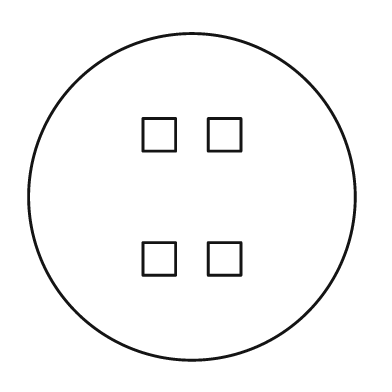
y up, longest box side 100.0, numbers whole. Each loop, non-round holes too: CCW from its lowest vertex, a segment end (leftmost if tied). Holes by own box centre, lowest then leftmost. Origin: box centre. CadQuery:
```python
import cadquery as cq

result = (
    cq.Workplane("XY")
    .moveTo(0.0, 0.0)
    .circle(50.0)
    .moveTo(-15.0, -24.0)
    .lineTo(-5.0, -24.0)
    .lineTo(-5.0, -14.0)
    .lineTo(-15.0, -14.0)
    .close()
    .moveTo(5.0, -24.0)
    .lineTo(15.0, -24.0)
    .lineTo(15.0, -14.0)
    .lineTo(5.0, -14.0)
    .close()
    .moveTo(-15.0, 14.0)
    .lineTo(-5.0, 14.0)
    .lineTo(-5.0, 24.0)
    .lineTo(-15.0, 24.0)
    .close()
    .moveTo(5.0, 14.0)
    .lineTo(15.0, 14.0)
    .lineTo(15.0, 24.0)
    .lineTo(5.0, 24.0)
    .close()
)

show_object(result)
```